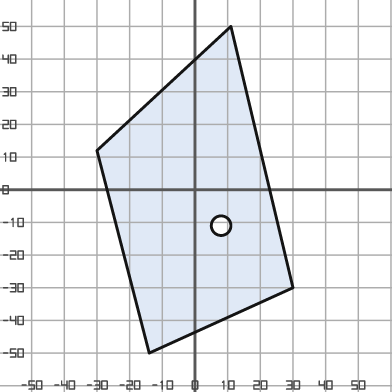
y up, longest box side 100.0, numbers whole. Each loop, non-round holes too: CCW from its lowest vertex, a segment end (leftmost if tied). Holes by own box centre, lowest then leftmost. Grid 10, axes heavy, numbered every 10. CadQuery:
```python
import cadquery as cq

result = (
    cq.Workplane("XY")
    .moveTo(-14.0, -50.0)
    .lineTo(30.0, -30.0)
    .lineTo(11.0, 50.0)
    .lineTo(-30.0, 12.0)
    .close()
    .moveTo(8.0, -11.0)
    .circle(3.0)
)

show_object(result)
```